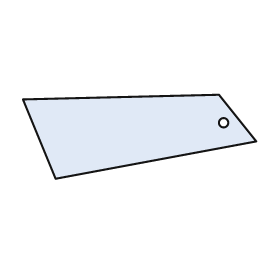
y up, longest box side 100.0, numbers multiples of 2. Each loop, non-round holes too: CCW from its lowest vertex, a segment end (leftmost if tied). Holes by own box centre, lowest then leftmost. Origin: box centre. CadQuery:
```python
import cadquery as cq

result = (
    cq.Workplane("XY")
    .moveTo(-36.0, -18.0)
    .lineTo(50.0, -2.0)
    .lineTo(34.0, 18.0)
    .lineTo(-50.0, 16.0)
    .close()
    .moveTo(36.0, 6.0)
    .circle(2.0)
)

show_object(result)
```